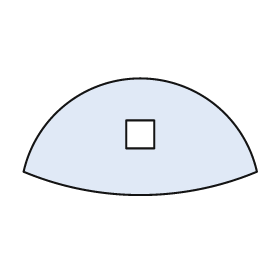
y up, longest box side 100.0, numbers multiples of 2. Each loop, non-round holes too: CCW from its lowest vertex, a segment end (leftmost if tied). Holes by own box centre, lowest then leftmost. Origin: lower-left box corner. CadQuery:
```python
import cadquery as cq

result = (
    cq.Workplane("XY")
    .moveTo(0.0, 10.0)
    .threePointArc((50.0, 0.0), (100.0, 10.0))
    .threePointArc((50.0, 50.0), (0.0, 10.0))
    .close()
    .moveTo(44.0, 20.0)
    .lineTo(56.0, 20.0)
    .lineTo(56.0, 32.0)
    .lineTo(44.0, 32.0)
    .close()
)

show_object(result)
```